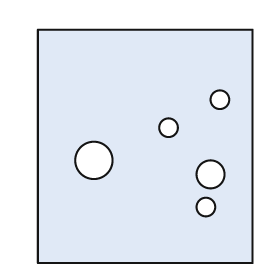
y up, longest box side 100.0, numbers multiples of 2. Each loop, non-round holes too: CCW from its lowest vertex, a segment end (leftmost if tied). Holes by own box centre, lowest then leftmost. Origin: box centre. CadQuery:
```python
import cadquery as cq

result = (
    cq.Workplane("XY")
    .moveTo(-46.0, -50.0)
    .lineTo(46.0, -50.0)
    .lineTo(46.0, 50.0)
    .lineTo(-46.0, 50.0)
    .close()
    .moveTo(26.0, -26.0)
    .circle(4.0)
    .moveTo(28.0, -12.0)
    .circle(6.0)
    .moveTo(-22.0, -6.0)
    .circle(8.0)
    .moveTo(10.0, 8.0)
    .circle(4.0)
    .moveTo(32.0, 20.0)
    .circle(4.0)
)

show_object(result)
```